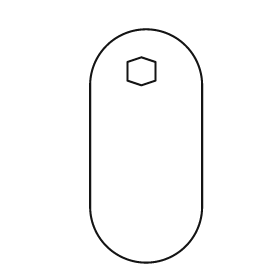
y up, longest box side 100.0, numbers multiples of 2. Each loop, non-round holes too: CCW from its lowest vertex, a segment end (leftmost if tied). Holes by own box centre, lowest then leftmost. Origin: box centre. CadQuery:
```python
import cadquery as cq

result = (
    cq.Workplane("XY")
    .moveTo(-24.0, -26.0)
    .threePointArc((0.0, -50.0), (24.0, -26.0))
    .lineTo(24.0, 26.0)
    .threePointArc((0.0, 50.0), (-24.0, 26.0))
    .close()
    .moveTo(-2.0, 26.0)
    .lineTo(4.0, 28.0)
    .lineTo(4.0, 36.0)
    .lineTo(-2.0, 38.0)
    .lineTo(-8.0, 36.0)
    .lineTo(-8.0, 28.0)
    .close()
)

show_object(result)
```